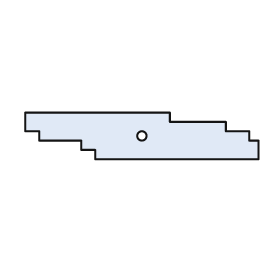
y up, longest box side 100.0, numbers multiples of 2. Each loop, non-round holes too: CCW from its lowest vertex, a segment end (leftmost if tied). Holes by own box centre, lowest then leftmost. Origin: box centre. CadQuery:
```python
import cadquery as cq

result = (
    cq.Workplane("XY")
    .moveTo(-20.0, -10.0)
    .lineTo(50.0, -10.0)
    .lineTo(50.0, -2.0)
    .lineTo(46.0, -2.0)
    .lineTo(46.0, 2.0)
    .lineTo(36.0, 2.0)
    .lineTo(36.0, 6.0)
    .lineTo(12.0, 6.0)
    .lineTo(12.0, 10.0)
    .lineTo(-50.0, 10.0)
    .lineTo(-50.0, 2.0)
    .lineTo(-44.0, 2.0)
    .lineTo(-44.0, -2.0)
    .lineTo(-26.0, -2.0)
    .lineTo(-26.0, -6.0)
    .lineTo(-20.0, -6.0)
    .close()
    .moveTo(0.0, 0.0)
    .circle(2.0)
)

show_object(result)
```